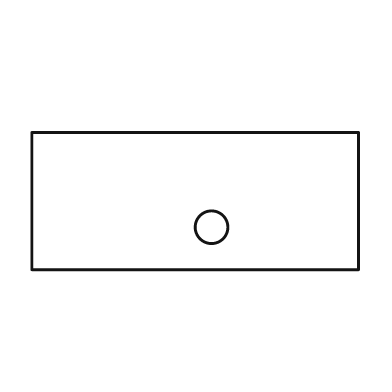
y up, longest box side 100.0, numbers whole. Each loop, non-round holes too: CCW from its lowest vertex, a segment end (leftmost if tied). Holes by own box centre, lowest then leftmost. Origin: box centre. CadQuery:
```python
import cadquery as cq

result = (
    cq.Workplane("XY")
    .moveTo(-50.0, -21.0)
    .lineTo(50.0, -21.0)
    .lineTo(50.0, 21.0)
    .lineTo(-50.0, 21.0)
    .close()
    .moveTo(5.0, -8.0)
    .circle(5.0)
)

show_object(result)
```